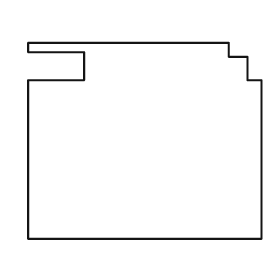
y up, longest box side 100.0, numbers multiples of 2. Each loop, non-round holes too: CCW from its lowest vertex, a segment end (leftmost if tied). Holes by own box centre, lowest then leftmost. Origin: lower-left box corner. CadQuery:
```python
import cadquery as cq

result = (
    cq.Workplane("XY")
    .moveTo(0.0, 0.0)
    .lineTo(100.0, 0.0)
    .lineTo(100.0, 68.0)
    .lineTo(94.0, 68.0)
    .lineTo(94.0, 78.0)
    .lineTo(86.0, 78.0)
    .lineTo(86.0, 84.0)
    .lineTo(0.0, 84.0)
    .lineTo(0.0, 80.0)
    .lineTo(24.0, 80.0)
    .lineTo(24.0, 68.0)
    .lineTo(0.0, 68.0)
    .close()
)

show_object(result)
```